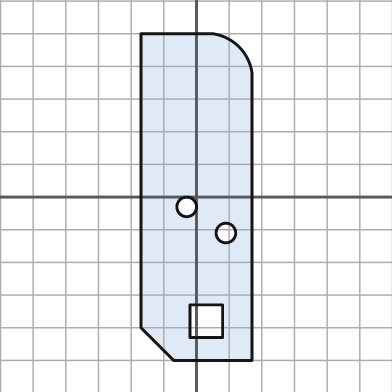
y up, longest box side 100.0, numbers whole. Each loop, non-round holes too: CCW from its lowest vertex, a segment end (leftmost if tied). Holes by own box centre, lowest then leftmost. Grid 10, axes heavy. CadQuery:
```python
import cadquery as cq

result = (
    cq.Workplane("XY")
    .moveTo(-7.0, -50.0)
    .lineTo(17.0, -50.0)
    .lineTo(17.0, 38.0)
    .threePointArc((13.0, 46.0), (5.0, 50.0))
    .lineTo(-17.0, 50.0)
    .lineTo(-17.0, -40.0)
    .close()
    .moveTo(-2.0, -43.0)
    .lineTo(8.0, -43.0)
    .lineTo(8.0, -33.0)
    .lineTo(-2.0, -33.0)
    .close()
    .moveTo(9.0, -11.0)
    .circle(3.0)
    .moveTo(-3.0, -3.0)
    .circle(3.0)
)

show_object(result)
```